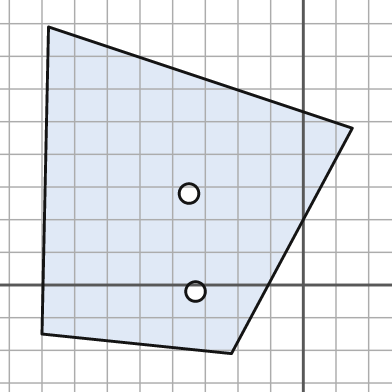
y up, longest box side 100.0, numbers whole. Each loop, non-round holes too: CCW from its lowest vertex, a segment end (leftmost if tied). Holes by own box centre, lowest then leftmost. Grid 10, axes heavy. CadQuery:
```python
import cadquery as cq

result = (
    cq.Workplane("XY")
    .moveTo(-22.0, -21.0)
    .lineTo(15.0, 48.0)
    .lineTo(-78.0, 79.0)
    .lineTo(-80.0, -15.0)
    .close()
    .moveTo(-33.0, -2.0)
    .circle(3.0)
    .moveTo(-35.0, 28.0)
    .circle(3.0)
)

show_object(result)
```